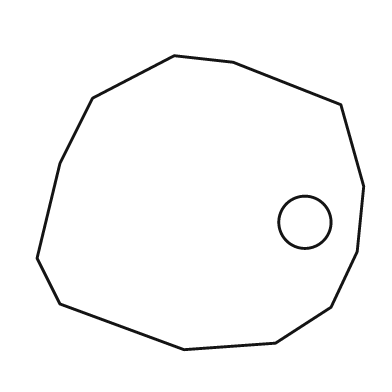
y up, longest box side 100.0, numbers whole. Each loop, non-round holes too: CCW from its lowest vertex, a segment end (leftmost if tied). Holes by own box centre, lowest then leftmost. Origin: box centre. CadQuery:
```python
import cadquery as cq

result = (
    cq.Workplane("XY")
    .moveTo(-5.0, -45.0)
    .lineTo(23.0, -43.0)
    .lineTo(40.0, -32.0)
    .lineTo(48.0, -15.0)
    .lineTo(50.0, 5.0)
    .lineTo(43.0, 30.0)
    .lineTo(10.0, 43.0)
    .lineTo(-8.0, 45.0)
    .lineTo(-33.0, 32.0)
    .lineTo(-43.0, 12.0)
    .lineTo(-50.0, -17.0)
    .lineTo(-43.0, -31.0)
    .close()
    .moveTo(32.0, -6.0)
    .circle(8.0)
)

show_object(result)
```